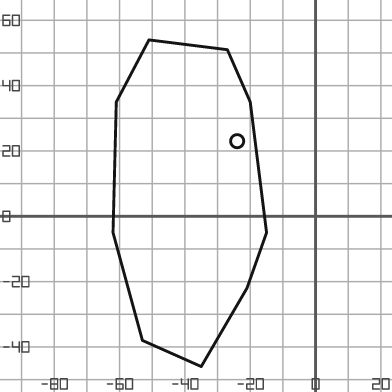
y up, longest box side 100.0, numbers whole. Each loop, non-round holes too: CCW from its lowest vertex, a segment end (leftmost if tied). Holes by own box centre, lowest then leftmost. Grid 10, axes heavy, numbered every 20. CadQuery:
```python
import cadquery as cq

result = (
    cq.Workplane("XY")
    .moveTo(-35.0, -46.0)
    .lineTo(-21.0, -22.0)
    .lineTo(-15.0, -5.0)
    .lineTo(-20.0, 35.0)
    .lineTo(-27.0, 51.0)
    .lineTo(-51.0, 54.0)
    .lineTo(-61.0, 35.0)
    .lineTo(-62.0, -5.0)
    .lineTo(-53.0, -38.0)
    .close()
    .moveTo(-24.0, 23.0)
    .circle(2.0)
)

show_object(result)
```